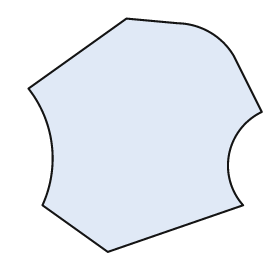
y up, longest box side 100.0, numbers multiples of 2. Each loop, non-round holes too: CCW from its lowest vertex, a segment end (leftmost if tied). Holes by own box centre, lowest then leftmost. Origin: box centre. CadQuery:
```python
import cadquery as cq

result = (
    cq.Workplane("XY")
    .moveTo(-16.0, -50.0)
    .lineTo(42.0, -30.0)
    .threePointArc((36.0, -8.0), (50.0, 10.0))
    .lineTo(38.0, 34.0)
    .threePointArc((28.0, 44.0), (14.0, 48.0))
    .lineTo(-8.0, 50.0)
    .lineTo(-50.0, 20.0)
    .threePointArc((-40.0, -4.0), (-44.0, -30.0))
    .close()
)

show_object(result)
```